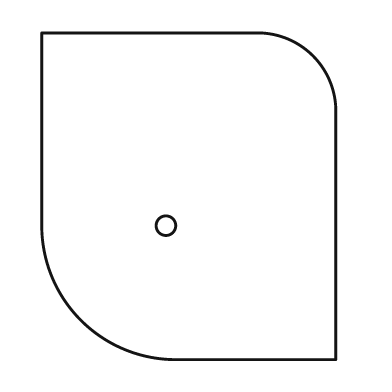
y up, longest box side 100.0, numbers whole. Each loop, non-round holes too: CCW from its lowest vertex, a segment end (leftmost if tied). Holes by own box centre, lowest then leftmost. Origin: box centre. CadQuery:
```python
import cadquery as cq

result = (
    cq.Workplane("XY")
    .moveTo(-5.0, -50.0)
    .lineTo(45.0, -50.0)
    .lineTo(45.0, 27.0)
    .threePointArc((38.0, 43.0), (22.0, 50.0))
    .lineTo(-45.0, 50.0)
    .lineTo(-45.0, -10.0)
    .threePointArc((-33.0, -38.0), (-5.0, -50.0))
    .close()
    .moveTo(-7.0, -9.0)
    .circle(3.0)
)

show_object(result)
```